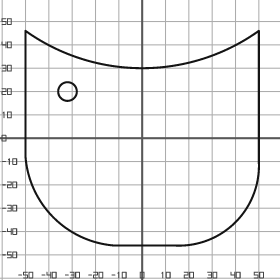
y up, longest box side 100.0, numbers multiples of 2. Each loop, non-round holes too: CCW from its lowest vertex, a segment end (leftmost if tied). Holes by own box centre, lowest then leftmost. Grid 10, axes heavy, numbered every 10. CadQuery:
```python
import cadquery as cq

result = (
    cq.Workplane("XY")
    .moveTo(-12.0, -46.0)
    .lineTo(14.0, -46.0)
    .threePointArc((40.0, -36.0), (50.0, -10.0))
    .lineTo(50.0, 46.0)
    .threePointArc((0.0, 30.0), (-50.0, 46.0))
    .lineTo(-50.0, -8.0)
    .threePointArc((-38.0, -34.0), (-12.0, -46.0))
    .close()
    .moveTo(-32.0, 20.0)
    .circle(4.0)
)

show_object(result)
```